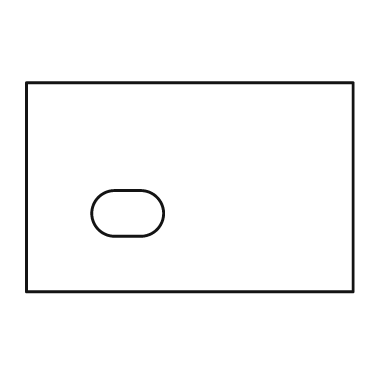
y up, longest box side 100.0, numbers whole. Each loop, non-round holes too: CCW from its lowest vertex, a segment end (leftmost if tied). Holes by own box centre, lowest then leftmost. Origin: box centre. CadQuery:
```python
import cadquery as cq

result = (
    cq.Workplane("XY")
    .moveTo(-50.0, -32.0)
    .lineTo(50.0, -32.0)
    .lineTo(50.0, 32.0)
    .lineTo(-50.0, 32.0)
    .close()
    .moveTo(-23.0, -15.0)
    .lineTo(-15.0, -15.0)
    .threePointArc((-8.0, -8.0), (-15.0, -1.0))
    .lineTo(-23.0, -1.0)
    .threePointArc((-30.0, -8.0), (-23.0, -15.0))
    .close()
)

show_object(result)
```